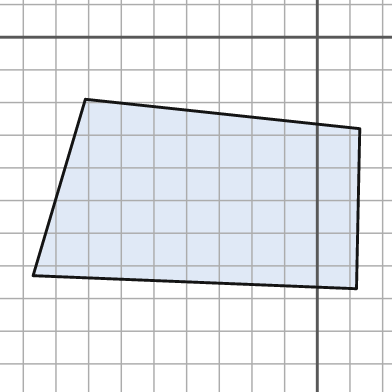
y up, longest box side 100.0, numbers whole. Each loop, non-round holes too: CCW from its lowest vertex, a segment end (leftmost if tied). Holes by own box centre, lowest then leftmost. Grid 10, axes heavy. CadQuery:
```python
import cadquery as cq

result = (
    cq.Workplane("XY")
    .moveTo(12.0, -77.0)
    .lineTo(13.0, -28.0)
    .lineTo(-71.0, -19.0)
    .lineTo(-87.0, -73.0)
    .close()
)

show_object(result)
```